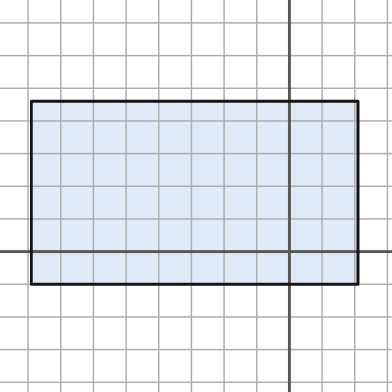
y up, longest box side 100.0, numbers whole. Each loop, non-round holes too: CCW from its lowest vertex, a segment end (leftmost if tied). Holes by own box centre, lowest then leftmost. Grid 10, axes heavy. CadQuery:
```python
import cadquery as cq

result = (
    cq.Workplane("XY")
    .moveTo(-79.0, -10.0)
    .lineTo(21.0, -10.0)
    .lineTo(21.0, 46.0)
    .lineTo(-79.0, 46.0)
    .close()
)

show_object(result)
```